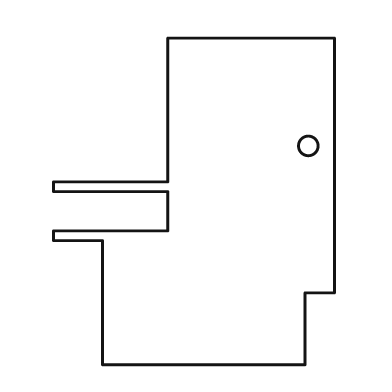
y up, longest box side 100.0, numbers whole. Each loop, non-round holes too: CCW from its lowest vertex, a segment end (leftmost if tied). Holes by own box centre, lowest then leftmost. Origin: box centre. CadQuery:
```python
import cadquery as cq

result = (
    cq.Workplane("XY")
    .moveTo(-28.0, -50.0)
    .lineTo(34.0, -50.0)
    .lineTo(34.0, -28.0)
    .lineTo(43.0, -28.0)
    .lineTo(43.0, 50.0)
    .lineTo(-8.0, 50.0)
    .lineTo(-8.0, 6.0)
    .lineTo(-43.0, 6.0)
    .lineTo(-43.0, 3.0)
    .lineTo(-8.0, 3.0)
    .lineTo(-8.0, -9.0)
    .lineTo(-43.0, -9.0)
    .lineTo(-43.0, -12.0)
    .lineTo(-28.0, -12.0)
    .close()
    .moveTo(35.0, 17.0)
    .circle(3.0)
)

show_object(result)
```